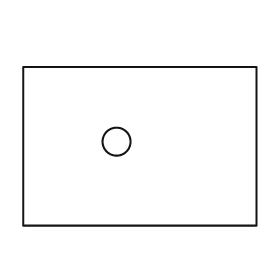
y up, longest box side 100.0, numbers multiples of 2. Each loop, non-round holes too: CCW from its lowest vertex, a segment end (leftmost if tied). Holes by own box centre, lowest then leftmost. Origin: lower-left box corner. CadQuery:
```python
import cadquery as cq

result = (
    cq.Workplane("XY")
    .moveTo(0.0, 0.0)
    .lineTo(100.0, 0.0)
    .lineTo(100.0, 68.0)
    .lineTo(0.0, 68.0)
    .close()
    .moveTo(40.0, 36.0)
    .circle(6.0)
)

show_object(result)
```